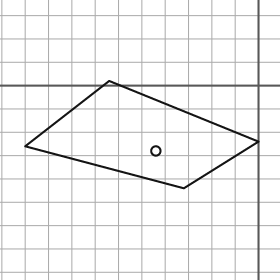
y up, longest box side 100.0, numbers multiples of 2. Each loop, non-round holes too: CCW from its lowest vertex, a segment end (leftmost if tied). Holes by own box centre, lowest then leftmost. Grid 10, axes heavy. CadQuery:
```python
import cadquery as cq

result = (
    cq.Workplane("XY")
    .moveTo(-32.0, -44.0)
    .lineTo(0.0, -24.0)
    .lineTo(-64.0, 2.0)
    .lineTo(-100.0, -26.0)
    .close()
    .moveTo(-44.0, -28.0)
    .circle(2.0)
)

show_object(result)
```